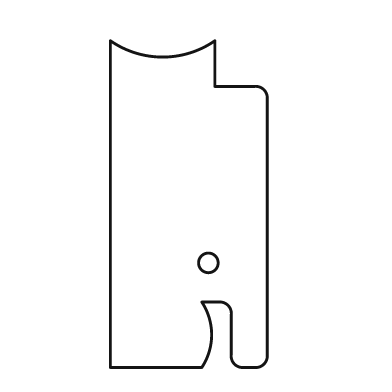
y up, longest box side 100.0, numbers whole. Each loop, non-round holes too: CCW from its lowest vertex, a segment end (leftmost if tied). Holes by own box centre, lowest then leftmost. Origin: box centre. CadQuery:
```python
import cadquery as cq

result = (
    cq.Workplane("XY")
    .moveTo(-24.0, -50.0)
    .lineTo(4.0, -50.0)
    .threePointArc((7.0, -40.0), (4.0, -30.0))
    .lineTo(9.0, -30.0)
    .threePointArc((12.0, -31.0), (13.0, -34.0))
    .lineTo(13.0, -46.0)
    .threePointArc((14.0, -49.0), (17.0, -50.0))
    .lineTo(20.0, -50.0)
    .threePointArc((23.0, -49.0), (24.0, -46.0))
    .lineTo(24.0, 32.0)
    .threePointArc((23.0, 35.0), (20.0, 36.0))
    .lineTo(8.0, 36.0)
    .lineTo(8.0, 50.0)
    .threePointArc((-8.0, 45.0), (-24.0, 50.0))
    .close()
    .moveTo(6.0, -18.0)
    .circle(3.0)
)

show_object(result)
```